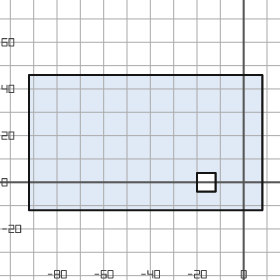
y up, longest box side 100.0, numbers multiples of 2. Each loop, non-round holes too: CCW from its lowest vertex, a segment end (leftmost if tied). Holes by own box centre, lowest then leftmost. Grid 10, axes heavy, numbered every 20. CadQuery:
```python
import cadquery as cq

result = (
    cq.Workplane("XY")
    .moveTo(-92.0, -12.0)
    .lineTo(8.0, -12.0)
    .lineTo(8.0, 46.0)
    .lineTo(-92.0, 46.0)
    .close()
    .moveTo(-20.0, -4.0)
    .lineTo(-12.0, -4.0)
    .lineTo(-12.0, 4.0)
    .lineTo(-20.0, 4.0)
    .close()
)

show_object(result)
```